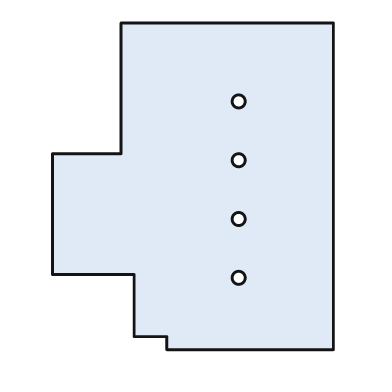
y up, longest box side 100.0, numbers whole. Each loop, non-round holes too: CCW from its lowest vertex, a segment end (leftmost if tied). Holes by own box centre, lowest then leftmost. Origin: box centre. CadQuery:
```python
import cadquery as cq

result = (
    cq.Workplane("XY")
    .moveTo(-8.0, -50.0)
    .lineTo(43.0, -50.0)
    .lineTo(43.0, 50.0)
    .lineTo(-22.0, 50.0)
    .lineTo(-22.0, 10.0)
    .lineTo(-43.0, 10.0)
    .lineTo(-43.0, -27.0)
    .lineTo(-18.0, -27.0)
    .lineTo(-18.0, -46.0)
    .lineTo(-8.0, -46.0)
    .close()
    .moveTo(14.0, -28.0)
    .circle(2.0)
    .moveTo(14.0, -10.0)
    .circle(2.0)
    .moveTo(14.0, 8.0)
    .circle(2.0)
    .moveTo(14.0, 26.0)
    .circle(2.0)
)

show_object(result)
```